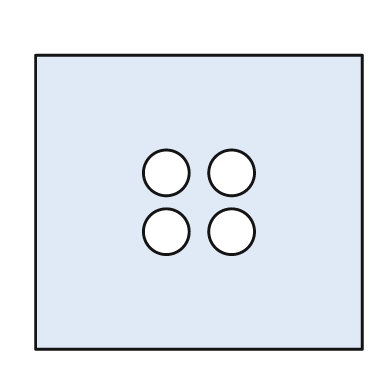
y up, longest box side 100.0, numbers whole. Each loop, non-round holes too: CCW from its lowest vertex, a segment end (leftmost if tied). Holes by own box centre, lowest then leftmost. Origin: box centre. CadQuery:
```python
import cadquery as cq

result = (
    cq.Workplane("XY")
    .moveTo(-50.0, -45.0)
    .lineTo(50.0, -45.0)
    .lineTo(50.0, 45.0)
    .lineTo(-50.0, 45.0)
    .close()
    .moveTo(-10.0, -9.0)
    .circle(7.0)
    .moveTo(10.0, -9.0)
    .circle(7.0)
    .moveTo(-10.0, 9.0)
    .circle(7.0)
    .moveTo(10.0, 9.0)
    .circle(7.0)
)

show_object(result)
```